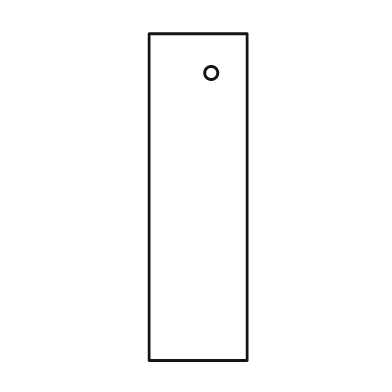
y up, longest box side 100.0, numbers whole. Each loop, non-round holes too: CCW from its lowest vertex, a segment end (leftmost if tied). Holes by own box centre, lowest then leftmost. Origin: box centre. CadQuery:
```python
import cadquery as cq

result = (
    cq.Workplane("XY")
    .moveTo(-15.0, -50.0)
    .lineTo(15.0, -50.0)
    .lineTo(15.0, 50.0)
    .lineTo(-15.0, 50.0)
    .close()
    .moveTo(4.0, 38.0)
    .circle(2.0)
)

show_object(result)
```